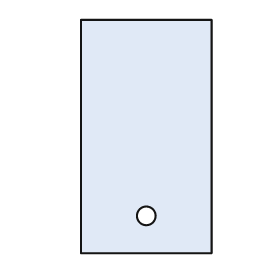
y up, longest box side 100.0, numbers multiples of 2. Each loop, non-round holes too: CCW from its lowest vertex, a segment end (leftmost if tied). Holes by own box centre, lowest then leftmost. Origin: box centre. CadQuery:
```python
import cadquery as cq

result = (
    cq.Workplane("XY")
    .moveTo(-28.0, -50.0)
    .lineTo(28.0, -50.0)
    .lineTo(28.0, 50.0)
    .lineTo(-28.0, 50.0)
    .close()
    .moveTo(0.0, -34.0)
    .circle(4.0)
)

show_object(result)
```